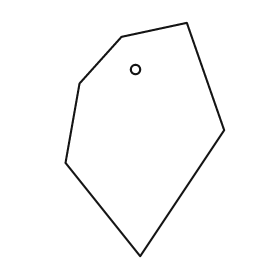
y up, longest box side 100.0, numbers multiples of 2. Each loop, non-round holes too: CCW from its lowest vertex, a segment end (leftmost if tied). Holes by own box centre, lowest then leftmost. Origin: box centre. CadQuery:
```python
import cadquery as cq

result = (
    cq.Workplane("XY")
    .moveTo(-2.0, -50.0)
    .lineTo(34.0, 4.0)
    .lineTo(18.0, 50.0)
    .lineTo(-10.0, 44.0)
    .lineTo(-28.0, 24.0)
    .lineTo(-34.0, -10.0)
    .close()
    .moveTo(-4.0, 30.0)
    .circle(2.0)
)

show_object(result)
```